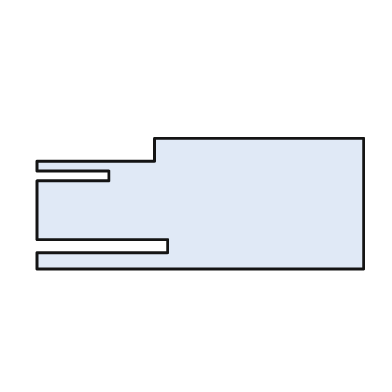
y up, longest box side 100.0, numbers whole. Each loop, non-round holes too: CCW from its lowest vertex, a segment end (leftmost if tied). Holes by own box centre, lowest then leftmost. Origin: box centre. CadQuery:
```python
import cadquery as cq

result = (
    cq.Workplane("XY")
    .moveTo(-50.0, -20.0)
    .lineTo(50.0, -20.0)
    .lineTo(50.0, 20.0)
    .lineTo(-14.0, 20.0)
    .lineTo(-14.0, 13.0)
    .lineTo(-50.0, 13.0)
    .lineTo(-50.0, 10.0)
    .lineTo(-28.0, 10.0)
    .lineTo(-28.0, 7.0)
    .lineTo(-50.0, 7.0)
    .lineTo(-50.0, -11.0)
    .lineTo(-10.0, -11.0)
    .lineTo(-10.0, -15.0)
    .lineTo(-50.0, -15.0)
    .close()
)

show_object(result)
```